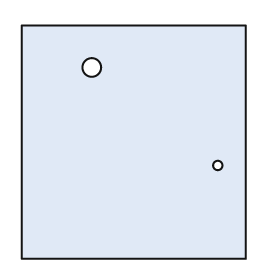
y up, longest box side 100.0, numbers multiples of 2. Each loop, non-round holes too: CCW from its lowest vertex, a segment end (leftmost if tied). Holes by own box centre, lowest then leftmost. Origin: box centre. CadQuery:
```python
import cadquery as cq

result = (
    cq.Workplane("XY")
    .moveTo(-48.0, -50.0)
    .lineTo(48.0, -50.0)
    .lineTo(48.0, 50.0)
    .lineTo(-48.0, 50.0)
    .close()
    .moveTo(36.0, -10.0)
    .circle(2.0)
    .moveTo(-18.0, 32.0)
    .circle(4.0)
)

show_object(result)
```